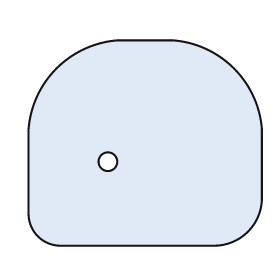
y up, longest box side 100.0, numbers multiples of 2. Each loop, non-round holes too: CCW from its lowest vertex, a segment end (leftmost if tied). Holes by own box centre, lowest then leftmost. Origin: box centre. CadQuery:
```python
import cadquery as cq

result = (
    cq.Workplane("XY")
    .moveTo(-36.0, -44.0)
    .lineTo(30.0, -44.0)
    .threePointArc((44.0, -38.0), (50.0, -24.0))
    .lineTo(50.0, 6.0)
    .threePointArc((38.0, 32.0), (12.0, 44.0))
    .lineTo(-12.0, 44.0)
    .threePointArc((-38.0, 32.0), (-50.0, 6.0))
    .lineTo(-50.0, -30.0)
    .threePointArc((-46.0, -40.0), (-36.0, -44.0))
    .close()
    .moveTo(-16.0, -8.0)
    .circle(4.0)
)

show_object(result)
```